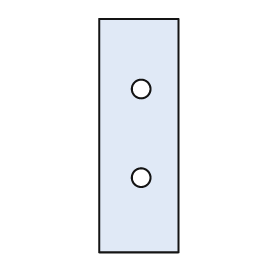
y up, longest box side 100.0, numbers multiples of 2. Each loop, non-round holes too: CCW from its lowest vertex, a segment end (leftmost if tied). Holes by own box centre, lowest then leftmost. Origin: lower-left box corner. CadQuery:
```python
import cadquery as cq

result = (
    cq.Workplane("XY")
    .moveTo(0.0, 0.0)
    .lineTo(34.0, 0.0)
    .lineTo(34.0, 100.0)
    .lineTo(0.0, 100.0)
    .close()
    .moveTo(18.0, 32.0)
    .circle(4.0)
    .moveTo(18.0, 70.0)
    .circle(4.0)
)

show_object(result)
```